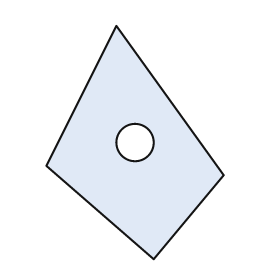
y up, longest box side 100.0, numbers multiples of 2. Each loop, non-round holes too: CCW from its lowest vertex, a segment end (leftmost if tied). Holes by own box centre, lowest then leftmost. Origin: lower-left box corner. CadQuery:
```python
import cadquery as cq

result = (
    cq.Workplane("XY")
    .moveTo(46.0, 0.0)
    .lineTo(76.0, 36.0)
    .lineTo(30.0, 100.0)
    .lineTo(0.0, 40.0)
    .close()
    .moveTo(38.0, 50.0)
    .circle(8.0)
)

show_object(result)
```